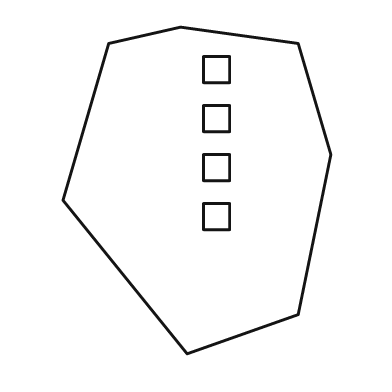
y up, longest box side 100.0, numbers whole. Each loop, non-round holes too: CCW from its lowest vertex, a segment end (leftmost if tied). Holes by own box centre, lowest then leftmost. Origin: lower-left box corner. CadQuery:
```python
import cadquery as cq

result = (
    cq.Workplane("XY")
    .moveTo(38.0, 0.0)
    .lineTo(72.0, 12.0)
    .lineTo(82.0, 61.0)
    .lineTo(72.0, 95.0)
    .lineTo(36.0, 100.0)
    .lineTo(14.0, 95.0)
    .lineTo(0.0, 47.0)
    .close()
    .moveTo(43.0, 38.0)
    .lineTo(51.0, 38.0)
    .lineTo(51.0, 46.0)
    .lineTo(43.0, 46.0)
    .close()
    .moveTo(43.0, 53.0)
    .lineTo(51.0, 53.0)
    .lineTo(51.0, 61.0)
    .lineTo(43.0, 61.0)
    .close()
    .moveTo(43.0, 68.0)
    .lineTo(51.0, 68.0)
    .lineTo(51.0, 76.0)
    .lineTo(43.0, 76.0)
    .close()
    .moveTo(43.0, 83.0)
    .lineTo(51.0, 83.0)
    .lineTo(51.0, 91.0)
    .lineTo(43.0, 91.0)
    .close()
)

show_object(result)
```